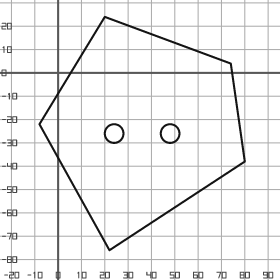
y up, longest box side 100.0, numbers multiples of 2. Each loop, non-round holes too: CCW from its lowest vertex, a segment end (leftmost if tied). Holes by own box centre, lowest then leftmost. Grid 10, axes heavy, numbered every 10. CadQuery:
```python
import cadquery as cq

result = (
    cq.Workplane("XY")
    .moveTo(22.0, -76.0)
    .lineTo(80.0, -38.0)
    .lineTo(74.0, 4.0)
    .lineTo(20.0, 24.0)
    .lineTo(-8.0, -22.0)
    .close()
    .moveTo(24.0, -26.0)
    .circle(4.0)
    .moveTo(48.0, -26.0)
    .circle(4.0)
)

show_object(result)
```